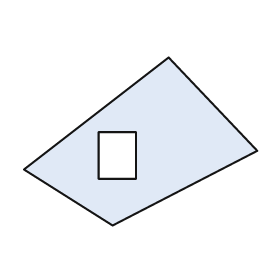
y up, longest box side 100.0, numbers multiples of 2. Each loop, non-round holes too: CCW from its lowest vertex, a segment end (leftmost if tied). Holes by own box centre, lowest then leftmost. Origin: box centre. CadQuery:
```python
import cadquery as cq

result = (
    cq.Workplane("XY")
    .moveTo(-12.0, -36.0)
    .lineTo(50.0, -4.0)
    .lineTo(12.0, 36.0)
    .lineTo(-50.0, -12.0)
    .close()
    .moveTo(-18.0, -16.0)
    .lineTo(-2.0, -16.0)
    .lineTo(-2.0, 4.0)
    .lineTo(-18.0, 4.0)
    .close()
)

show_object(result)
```